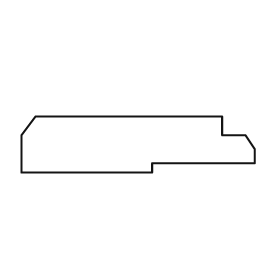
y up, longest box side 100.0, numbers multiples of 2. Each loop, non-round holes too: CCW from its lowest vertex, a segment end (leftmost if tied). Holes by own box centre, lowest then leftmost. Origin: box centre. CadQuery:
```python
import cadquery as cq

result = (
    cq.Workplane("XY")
    .moveTo(-50.0, -12.0)
    .lineTo(6.0, -12.0)
    .lineTo(6.0, -8.0)
    .lineTo(50.0, -8.0)
    .lineTo(50.0, -2.0)
    .lineTo(46.0, 4.0)
    .lineTo(36.0, 4.0)
    .lineTo(36.0, 12.0)
    .lineTo(-44.0, 12.0)
    .lineTo(-50.0, 4.0)
    .close()
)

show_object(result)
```